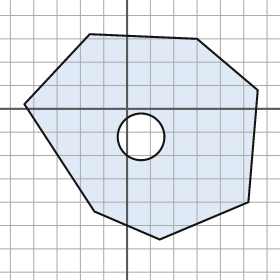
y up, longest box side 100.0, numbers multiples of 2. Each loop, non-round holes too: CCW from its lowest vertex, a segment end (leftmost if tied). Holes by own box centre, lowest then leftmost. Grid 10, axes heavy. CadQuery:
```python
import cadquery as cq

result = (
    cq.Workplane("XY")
    .moveTo(14.0, -56.0)
    .lineTo(52.0, -40.0)
    .lineTo(56.0, 8.0)
    .lineTo(30.0, 30.0)
    .lineTo(-16.0, 32.0)
    .lineTo(-44.0, 2.0)
    .lineTo(-14.0, -44.0)
    .close()
    .moveTo(6.0, -12.0)
    .circle(10.0)
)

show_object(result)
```